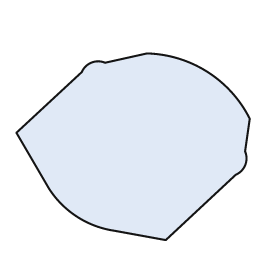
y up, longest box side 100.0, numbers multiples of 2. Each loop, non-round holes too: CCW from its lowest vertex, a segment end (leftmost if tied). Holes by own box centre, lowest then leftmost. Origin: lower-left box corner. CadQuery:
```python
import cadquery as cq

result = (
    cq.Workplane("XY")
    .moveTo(64.0, 0.0)
    .lineTo(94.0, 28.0)
    .threePointArc((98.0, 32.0), (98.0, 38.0))
    .lineTo(100.0, 52.0)
    .threePointArc((82.0, 72.0), (56.0, 80.0))
    .lineTo(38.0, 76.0)
    .threePointArc((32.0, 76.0), (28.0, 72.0))
    .lineTo(0.0, 46.0)
    .lineTo(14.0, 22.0)
    .threePointArc((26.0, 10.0), (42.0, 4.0))
    .close()
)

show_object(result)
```